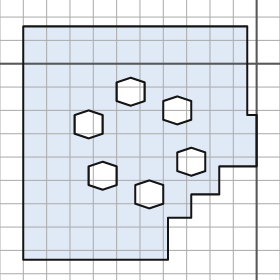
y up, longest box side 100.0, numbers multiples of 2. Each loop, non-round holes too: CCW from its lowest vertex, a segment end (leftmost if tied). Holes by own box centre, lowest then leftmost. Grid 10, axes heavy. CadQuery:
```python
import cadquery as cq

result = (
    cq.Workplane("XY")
    .moveTo(-100.0, -84.0)
    .lineTo(-38.0, -84.0)
    .lineTo(-38.0, -66.0)
    .lineTo(-28.0, -66.0)
    .lineTo(-28.0, -56.0)
    .lineTo(-16.0, -56.0)
    .lineTo(-16.0, -44.0)
    .lineTo(0.0, -44.0)
    .lineTo(0.0, -22.0)
    .lineTo(-4.0, -22.0)
    .lineTo(-4.0, 16.0)
    .lineTo(-100.0, 16.0)
    .close()
    .moveTo(-46.0, -62.0)
    .lineTo(-40.0, -60.0)
    .lineTo(-40.0, -52.0)
    .lineTo(-46.0, -50.0)
    .lineTo(-52.0, -52.0)
    .lineTo(-52.0, -60.0)
    .close()
    .moveTo(-66.0, -54.0)
    .lineTo(-60.0, -52.0)
    .lineTo(-60.0, -44.0)
    .lineTo(-66.0, -42.0)
    .lineTo(-72.0, -44.0)
    .lineTo(-72.0, -52.0)
    .close()
    .moveTo(-28.0, -48.0)
    .lineTo(-22.0, -46.0)
    .lineTo(-22.0, -38.0)
    .lineTo(-28.0, -36.0)
    .lineTo(-34.0, -38.0)
    .lineTo(-34.0, -46.0)
    .close()
    .moveTo(-72.0, -32.0)
    .lineTo(-66.0, -30.0)
    .lineTo(-66.0, -22.0)
    .lineTo(-72.0, -20.0)
    .lineTo(-78.0, -22.0)
    .lineTo(-78.0, -30.0)
    .close()
    .moveTo(-34.0, -26.0)
    .lineTo(-28.0, -24.0)
    .lineTo(-28.0, -16.0)
    .lineTo(-34.0, -14.0)
    .lineTo(-40.0, -16.0)
    .lineTo(-40.0, -24.0)
    .close()
    .moveTo(-54.0, -18.0)
    .lineTo(-48.0, -16.0)
    .lineTo(-48.0, -8.0)
    .lineTo(-54.0, -6.0)
    .lineTo(-60.0, -8.0)
    .lineTo(-60.0, -16.0)
    .close()
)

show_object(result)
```